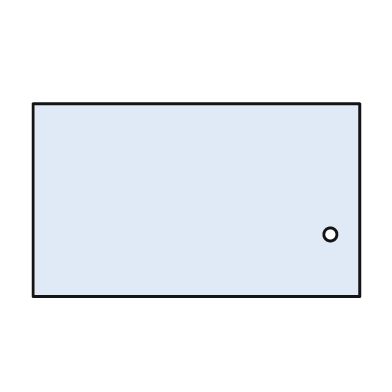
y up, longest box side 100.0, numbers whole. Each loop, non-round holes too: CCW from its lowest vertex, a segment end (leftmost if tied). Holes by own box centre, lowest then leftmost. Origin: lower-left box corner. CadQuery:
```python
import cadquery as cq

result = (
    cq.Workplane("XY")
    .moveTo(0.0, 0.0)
    .lineTo(100.0, 0.0)
    .lineTo(100.0, 59.0)
    .lineTo(0.0, 59.0)
    .close()
    .moveTo(91.0, 19.0)
    .circle(2.0)
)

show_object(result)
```